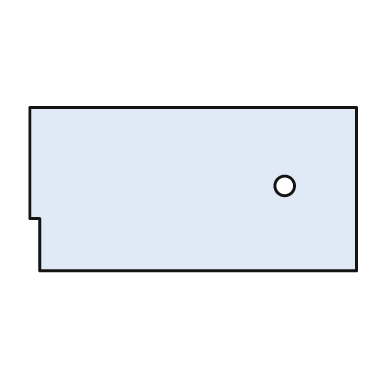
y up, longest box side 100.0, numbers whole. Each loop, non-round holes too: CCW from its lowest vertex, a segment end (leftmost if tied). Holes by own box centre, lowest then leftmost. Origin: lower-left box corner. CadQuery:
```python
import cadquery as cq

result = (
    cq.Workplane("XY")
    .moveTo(3.0, 0.0)
    .lineTo(100.0, 0.0)
    .lineTo(100.0, 50.0)
    .lineTo(0.0, 50.0)
    .lineTo(0.0, 16.0)
    .lineTo(3.0, 16.0)
    .close()
    .moveTo(78.0, 26.0)
    .circle(3.0)
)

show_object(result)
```